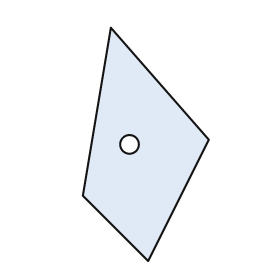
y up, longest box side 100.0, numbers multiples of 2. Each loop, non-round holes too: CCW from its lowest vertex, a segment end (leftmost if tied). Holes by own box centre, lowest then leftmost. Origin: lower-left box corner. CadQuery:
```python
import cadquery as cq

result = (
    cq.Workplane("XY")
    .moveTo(28.0, 0.0)
    .lineTo(54.0, 52.0)
    .lineTo(12.0, 100.0)
    .lineTo(0.0, 28.0)
    .close()
    .moveTo(20.0, 50.0)
    .circle(4.0)
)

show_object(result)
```